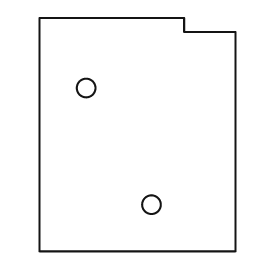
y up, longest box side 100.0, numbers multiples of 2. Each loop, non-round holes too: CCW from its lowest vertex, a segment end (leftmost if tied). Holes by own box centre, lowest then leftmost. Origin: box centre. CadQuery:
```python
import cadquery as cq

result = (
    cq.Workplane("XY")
    .moveTo(-42.0, -50.0)
    .lineTo(42.0, -50.0)
    .lineTo(42.0, 44.0)
    .lineTo(20.0, 44.0)
    .lineTo(20.0, 50.0)
    .lineTo(-42.0, 50.0)
    .close()
    .moveTo(6.0, -30.0)
    .circle(4.0)
    .moveTo(-22.0, 20.0)
    .circle(4.0)
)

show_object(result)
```